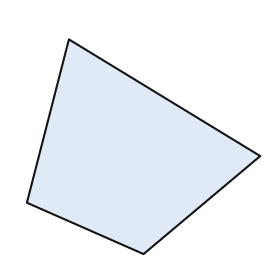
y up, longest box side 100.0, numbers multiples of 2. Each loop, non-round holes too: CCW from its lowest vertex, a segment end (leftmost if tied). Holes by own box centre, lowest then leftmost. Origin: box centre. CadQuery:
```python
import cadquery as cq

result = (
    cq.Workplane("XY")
    .moveTo(0.0, -46.0)
    .lineTo(50.0, -4.0)
    .lineTo(-32.0, 46.0)
    .lineTo(-50.0, -24.0)
    .close()
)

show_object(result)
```